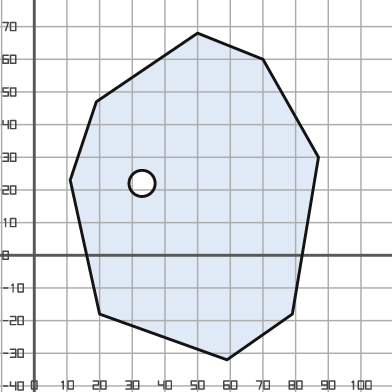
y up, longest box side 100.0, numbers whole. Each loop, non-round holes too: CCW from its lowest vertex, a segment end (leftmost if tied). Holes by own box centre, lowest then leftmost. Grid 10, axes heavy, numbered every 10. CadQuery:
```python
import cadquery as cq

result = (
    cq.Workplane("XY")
    .moveTo(59.0, -32.0)
    .lineTo(79.0, -18.0)
    .lineTo(87.0, 30.0)
    .lineTo(70.0, 60.0)
    .lineTo(50.0, 68.0)
    .lineTo(19.0, 47.0)
    .lineTo(11.0, 23.0)
    .lineTo(20.0, -18.0)
    .close()
    .moveTo(33.0, 22.0)
    .circle(4.0)
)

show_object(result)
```